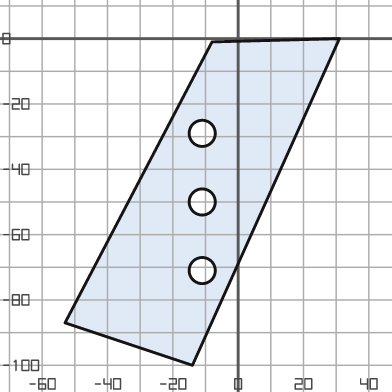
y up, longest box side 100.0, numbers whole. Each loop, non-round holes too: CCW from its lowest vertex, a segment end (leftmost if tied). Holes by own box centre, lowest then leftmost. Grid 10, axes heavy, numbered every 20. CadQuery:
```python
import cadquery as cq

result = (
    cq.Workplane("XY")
    .moveTo(-14.0, -100.0)
    .lineTo(31.0, 0.0)
    .lineTo(-8.0, -1.0)
    .lineTo(-53.0, -87.0)
    .close()
    .moveTo(-11.0, -71.0)
    .circle(4.0)
    .moveTo(-11.0, -50.0)
    .circle(4.0)
    .moveTo(-11.0, -29.0)
    .circle(4.0)
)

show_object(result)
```